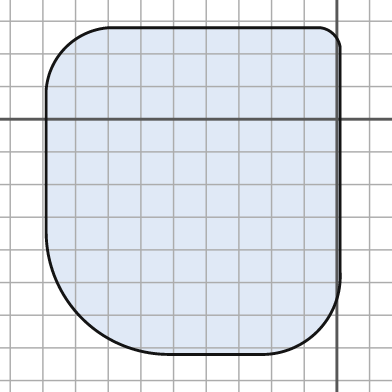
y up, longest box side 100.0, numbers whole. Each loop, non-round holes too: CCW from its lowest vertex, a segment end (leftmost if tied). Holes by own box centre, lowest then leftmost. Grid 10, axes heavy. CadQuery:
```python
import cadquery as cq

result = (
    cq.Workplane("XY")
    .moveTo(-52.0, -72.0)
    .lineTo(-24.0, -72.0)
    .threePointArc((-6.0, -65.0), (1.0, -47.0))
    .lineTo(1.0, 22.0)
    .threePointArc((-1.0, 26.0), (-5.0, 28.0))
    .lineTo(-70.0, 28.0)
    .threePointArc((-83.0, 22.0), (-89.0, 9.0))
    .lineTo(-89.0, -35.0)
    .threePointArc((-78.0, -61.0), (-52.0, -72.0))
    .close()
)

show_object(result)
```